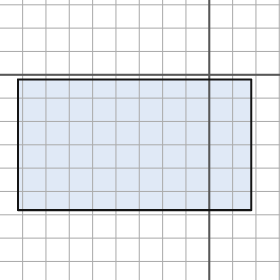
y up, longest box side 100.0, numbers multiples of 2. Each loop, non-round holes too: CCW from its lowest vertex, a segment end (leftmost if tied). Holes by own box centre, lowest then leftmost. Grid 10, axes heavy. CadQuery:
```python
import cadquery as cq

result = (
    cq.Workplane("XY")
    .moveTo(-82.0, -58.0)
    .lineTo(18.0, -58.0)
    .lineTo(18.0, -2.0)
    .lineTo(-82.0, -2.0)
    .close()
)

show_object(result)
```